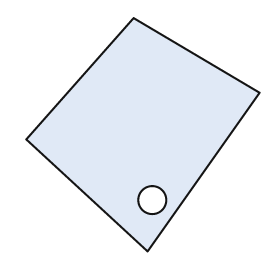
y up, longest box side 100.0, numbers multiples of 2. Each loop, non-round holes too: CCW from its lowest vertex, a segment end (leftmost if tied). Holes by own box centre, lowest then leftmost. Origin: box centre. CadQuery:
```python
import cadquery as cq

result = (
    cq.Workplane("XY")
    .moveTo(2.0, -50.0)
    .lineTo(50.0, 18.0)
    .lineTo(-4.0, 50.0)
    .lineTo(-50.0, -2.0)
    .close()
    .moveTo(4.0, -28.0)
    .circle(6.0)
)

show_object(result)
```